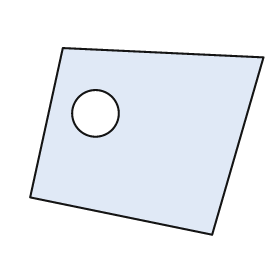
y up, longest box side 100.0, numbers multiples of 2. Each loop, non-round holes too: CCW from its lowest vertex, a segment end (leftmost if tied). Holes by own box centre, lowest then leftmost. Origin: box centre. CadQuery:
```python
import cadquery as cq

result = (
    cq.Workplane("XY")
    .moveTo(28.0, -40.0)
    .lineTo(50.0, 36.0)
    .lineTo(-36.0, 40.0)
    .lineTo(-50.0, -24.0)
    .close()
    .moveTo(-22.0, 12.0)
    .circle(10.0)
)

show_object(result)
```